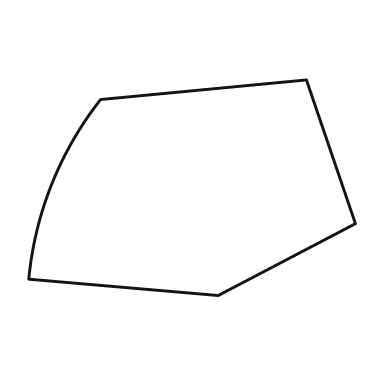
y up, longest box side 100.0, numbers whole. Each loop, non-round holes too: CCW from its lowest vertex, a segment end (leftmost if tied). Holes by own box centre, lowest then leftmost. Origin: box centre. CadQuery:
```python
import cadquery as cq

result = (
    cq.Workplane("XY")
    .moveTo(8.0, -33.0)
    .lineTo(50.0, -11.0)
    .lineTo(35.0, 33.0)
    .lineTo(-28.0, 27.0)
    .threePointArc((-43.0, 1.0), (-50.0, -28.0))
    .close()
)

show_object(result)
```